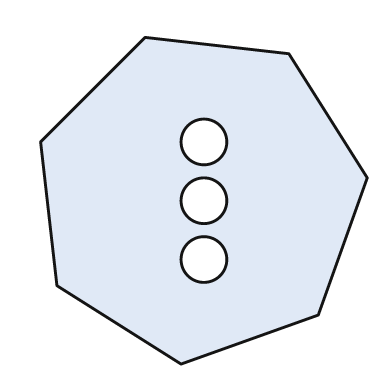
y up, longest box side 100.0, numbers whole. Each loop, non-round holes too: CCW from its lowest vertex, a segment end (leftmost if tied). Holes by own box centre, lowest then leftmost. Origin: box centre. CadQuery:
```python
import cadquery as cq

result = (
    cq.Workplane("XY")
    .moveTo(-7.0, -50.0)
    .lineTo(35.0, -35.0)
    .lineTo(50.0, 7.0)
    .lineTo(26.0, 45.0)
    .lineTo(-18.0, 50.0)
    .lineTo(-50.0, 18.0)
    .lineTo(-45.0, -26.0)
    .close()
    .moveTo(0.0, -18.0)
    .circle(7.0)
    .moveTo(0.0, 0.0)
    .circle(7.0)
    .moveTo(0.0, 18.0)
    .circle(7.0)
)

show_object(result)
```